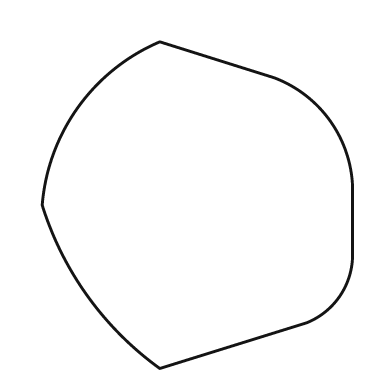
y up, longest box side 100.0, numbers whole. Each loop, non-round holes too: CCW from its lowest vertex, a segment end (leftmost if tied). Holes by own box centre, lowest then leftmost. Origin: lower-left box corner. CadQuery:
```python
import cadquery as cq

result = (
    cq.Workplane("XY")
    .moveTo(36.0, 0.0)
    .lineTo(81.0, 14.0)
    .threePointArc((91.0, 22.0), (95.0, 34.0))
    .lineTo(95.0, 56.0)
    .threePointArc((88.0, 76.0), (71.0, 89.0))
    .lineTo(36.0, 100.0)
    .threePointArc((11.0, 80.0), (0.0, 50.0))
    .threePointArc((14.0, 22.0), (36.0, 0.0))
    .close()
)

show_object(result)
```